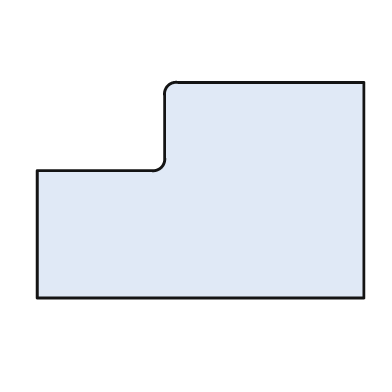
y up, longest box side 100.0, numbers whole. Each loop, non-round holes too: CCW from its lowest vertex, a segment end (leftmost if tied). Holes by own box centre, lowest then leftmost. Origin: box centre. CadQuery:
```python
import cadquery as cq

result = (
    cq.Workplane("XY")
    .moveTo(-50.0, -33.0)
    .lineTo(50.0, -33.0)
    .lineTo(50.0, 33.0)
    .lineTo(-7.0, 33.0)
    .threePointArc((-10.0, 32.0), (-11.0, 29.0))
    .lineTo(-11.0, 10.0)
    .threePointArc((-12.0, 7.0), (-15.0, 6.0))
    .lineTo(-50.0, 6.0)
    .close()
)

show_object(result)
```